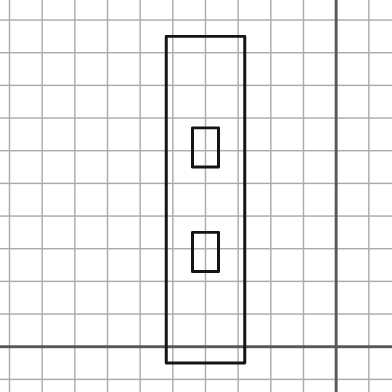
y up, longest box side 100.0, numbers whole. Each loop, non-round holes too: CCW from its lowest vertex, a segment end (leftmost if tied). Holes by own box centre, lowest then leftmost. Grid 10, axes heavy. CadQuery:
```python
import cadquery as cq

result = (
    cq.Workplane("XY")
    .moveTo(-52.0, -5.0)
    .lineTo(-28.0, -5.0)
    .lineTo(-28.0, 95.0)
    .lineTo(-52.0, 95.0)
    .close()
    .moveTo(-44.0, 23.0)
    .lineTo(-36.0, 23.0)
    .lineTo(-36.0, 35.0)
    .lineTo(-44.0, 35.0)
    .close()
    .moveTo(-44.0, 55.0)
    .lineTo(-36.0, 55.0)
    .lineTo(-36.0, 67.0)
    .lineTo(-44.0, 67.0)
    .close()
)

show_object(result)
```